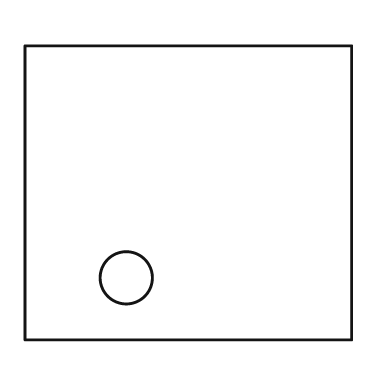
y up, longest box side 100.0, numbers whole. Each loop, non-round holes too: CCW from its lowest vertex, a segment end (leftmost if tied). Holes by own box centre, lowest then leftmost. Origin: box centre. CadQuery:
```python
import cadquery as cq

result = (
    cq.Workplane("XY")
    .moveTo(-50.0, -45.0)
    .lineTo(50.0, -45.0)
    .lineTo(50.0, 45.0)
    .lineTo(-50.0, 45.0)
    .close()
    .moveTo(-19.0, -26.0)
    .circle(8.0)
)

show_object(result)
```